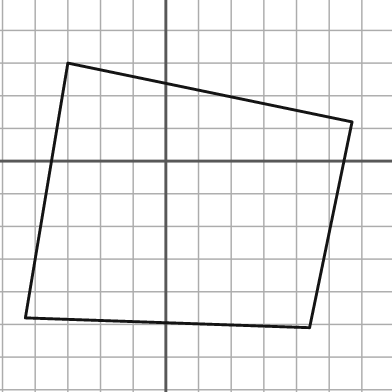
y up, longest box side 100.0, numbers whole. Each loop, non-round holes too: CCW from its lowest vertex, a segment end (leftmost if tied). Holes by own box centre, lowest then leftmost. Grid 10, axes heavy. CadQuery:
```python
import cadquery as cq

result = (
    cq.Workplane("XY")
    .moveTo(44.0, -51.0)
    .lineTo(57.0, 12.0)
    .lineTo(-30.0, 30.0)
    .lineTo(-43.0, -48.0)
    .close()
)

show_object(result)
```